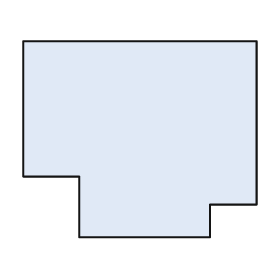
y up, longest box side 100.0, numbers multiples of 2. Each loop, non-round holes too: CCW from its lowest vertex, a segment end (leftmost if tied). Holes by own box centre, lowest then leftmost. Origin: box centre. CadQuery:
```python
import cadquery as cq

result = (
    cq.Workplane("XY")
    .moveTo(-26.0, -42.0)
    .lineTo(30.0, -42.0)
    .lineTo(30.0, -28.0)
    .lineTo(50.0, -28.0)
    .lineTo(50.0, 42.0)
    .lineTo(-50.0, 42.0)
    .lineTo(-50.0, -16.0)
    .lineTo(-26.0, -16.0)
    .close()
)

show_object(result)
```